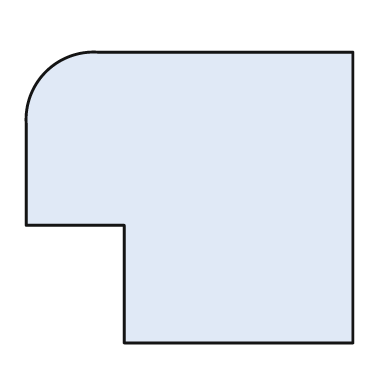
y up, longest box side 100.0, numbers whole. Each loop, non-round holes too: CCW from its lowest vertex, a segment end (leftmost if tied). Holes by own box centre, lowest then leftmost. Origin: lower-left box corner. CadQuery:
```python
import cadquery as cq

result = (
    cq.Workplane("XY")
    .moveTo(30.0, 0.0)
    .lineTo(100.0, 0.0)
    .lineTo(100.0, 89.0)
    .lineTo(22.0, 89.0)
    .threePointArc((6.0, 83.0), (0.0, 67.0))
    .lineTo(0.0, 36.0)
    .lineTo(30.0, 36.0)
    .close()
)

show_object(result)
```